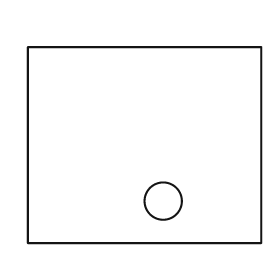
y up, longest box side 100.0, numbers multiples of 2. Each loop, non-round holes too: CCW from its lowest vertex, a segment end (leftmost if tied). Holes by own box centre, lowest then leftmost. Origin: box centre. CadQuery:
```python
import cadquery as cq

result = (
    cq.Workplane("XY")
    .moveTo(-50.0, -42.0)
    .lineTo(50.0, -42.0)
    .lineTo(50.0, 42.0)
    .lineTo(-50.0, 42.0)
    .close()
    .moveTo(8.0, -24.0)
    .circle(8.0)
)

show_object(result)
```